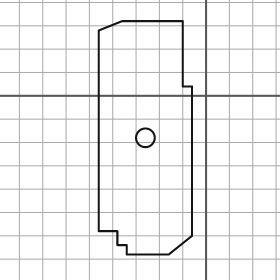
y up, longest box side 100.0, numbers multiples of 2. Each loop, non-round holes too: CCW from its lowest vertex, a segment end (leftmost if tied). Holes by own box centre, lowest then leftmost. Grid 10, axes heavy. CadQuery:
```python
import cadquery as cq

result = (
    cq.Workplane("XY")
    .moveTo(-34.0, -68.0)
    .lineTo(-16.0, -68.0)
    .lineTo(-6.0, -60.0)
    .lineTo(-6.0, 4.0)
    .lineTo(-10.0, 4.0)
    .lineTo(-10.0, 32.0)
    .lineTo(-36.0, 32.0)
    .lineTo(-46.0, 28.0)
    .lineTo(-46.0, -58.0)
    .lineTo(-38.0, -58.0)
    .lineTo(-38.0, -64.0)
    .lineTo(-34.0, -64.0)
    .close()
    .moveTo(-26.0, -18.0)
    .circle(4.0)
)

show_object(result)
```